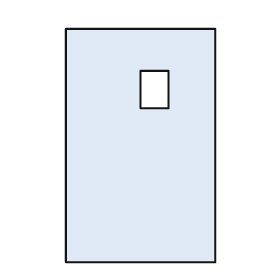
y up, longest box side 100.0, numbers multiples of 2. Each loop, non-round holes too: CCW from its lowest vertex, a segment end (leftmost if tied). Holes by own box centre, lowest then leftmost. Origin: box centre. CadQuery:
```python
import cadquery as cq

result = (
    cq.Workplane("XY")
    .moveTo(-32.0, -50.0)
    .lineTo(32.0, -50.0)
    .lineTo(32.0, 50.0)
    .lineTo(-32.0, 50.0)
    .close()
    .moveTo(0.0, 16.0)
    .lineTo(12.0, 16.0)
    .lineTo(12.0, 32.0)
    .lineTo(0.0, 32.0)
    .close()
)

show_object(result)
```